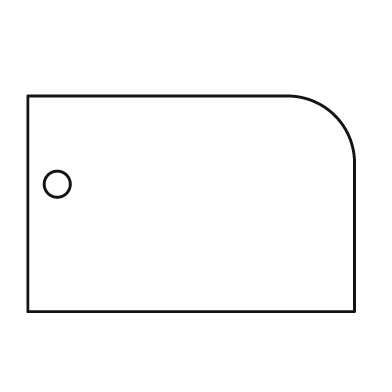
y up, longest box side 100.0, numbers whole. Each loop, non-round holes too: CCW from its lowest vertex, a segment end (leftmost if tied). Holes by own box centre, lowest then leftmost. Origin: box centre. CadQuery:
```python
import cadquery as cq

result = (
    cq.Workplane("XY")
    .moveTo(-50.0, -33.0)
    .lineTo(50.0, -33.0)
    .lineTo(50.0, 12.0)
    .threePointArc((44.0, 27.0), (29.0, 33.0))
    .lineTo(-50.0, 33.0)
    .close()
    .moveTo(-41.0, 6.0)
    .circle(4.0)
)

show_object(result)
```